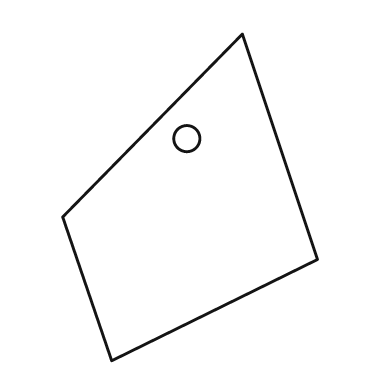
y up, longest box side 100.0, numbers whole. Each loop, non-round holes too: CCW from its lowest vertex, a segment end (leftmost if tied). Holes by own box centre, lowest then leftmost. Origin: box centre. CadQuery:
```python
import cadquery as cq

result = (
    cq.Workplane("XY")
    .moveTo(-24.0, -50.0)
    .lineTo(39.0, -19.0)
    .lineTo(16.0, 50.0)
    .lineTo(-39.0, -6.0)
    .close()
    .moveTo(-1.0, 18.0)
    .circle(4.0)
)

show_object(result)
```